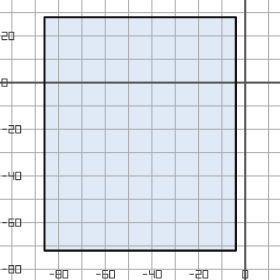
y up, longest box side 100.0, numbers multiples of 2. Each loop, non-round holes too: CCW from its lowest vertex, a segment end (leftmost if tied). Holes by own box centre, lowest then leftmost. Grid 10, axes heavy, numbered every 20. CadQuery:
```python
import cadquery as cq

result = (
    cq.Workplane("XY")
    .moveTo(-86.0, -72.0)
    .lineTo(-4.0, -72.0)
    .lineTo(-4.0, 28.0)
    .lineTo(-86.0, 28.0)
    .close()
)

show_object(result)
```